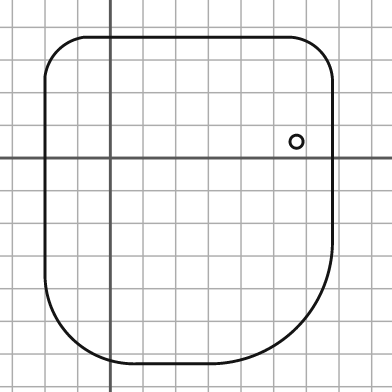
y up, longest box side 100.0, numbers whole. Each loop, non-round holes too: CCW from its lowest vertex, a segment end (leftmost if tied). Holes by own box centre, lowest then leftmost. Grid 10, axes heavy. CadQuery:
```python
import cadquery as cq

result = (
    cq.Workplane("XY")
    .moveTo(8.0, -63.0)
    .lineTo(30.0, -63.0)
    .threePointArc((57.0, -52.0), (68.0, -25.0))
    .lineTo(68.0, 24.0)
    .threePointArc((64.0, 33.0), (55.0, 37.0))
    .lineTo(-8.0, 37.0)
    .threePointArc((-16.0, 33.0), (-20.0, 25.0))
    .lineTo(-20.0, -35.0)
    .threePointArc((-12.0, -55.0), (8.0, -63.0))
    .close()
    .moveTo(57.0, 5.0)
    .circle(2.0)
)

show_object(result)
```